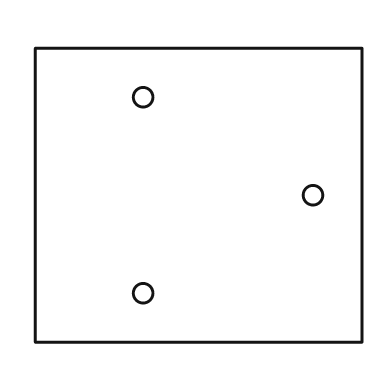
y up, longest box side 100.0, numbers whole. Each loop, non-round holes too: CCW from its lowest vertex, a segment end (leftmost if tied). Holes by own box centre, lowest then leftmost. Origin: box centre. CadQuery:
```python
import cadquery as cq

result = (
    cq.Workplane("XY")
    .moveTo(-50.0, -45.0)
    .lineTo(50.0, -45.0)
    .lineTo(50.0, 45.0)
    .lineTo(-50.0, 45.0)
    .close()
    .moveTo(-17.0, -30.0)
    .circle(3.0)
    .moveTo(35.0, 0.0)
    .circle(3.0)
    .moveTo(-17.0, 30.0)
    .circle(3.0)
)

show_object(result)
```